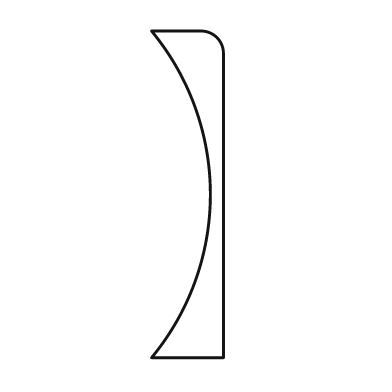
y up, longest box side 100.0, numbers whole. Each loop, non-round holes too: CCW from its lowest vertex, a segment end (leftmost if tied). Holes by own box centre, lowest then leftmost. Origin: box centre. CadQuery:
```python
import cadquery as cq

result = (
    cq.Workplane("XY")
    .moveTo(-11.0, -50.0)
    .lineTo(11.0, -50.0)
    .lineTo(11.0, 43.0)
    .threePointArc((9.0, 48.0), (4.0, 50.0))
    .lineTo(-11.0, 50.0)
    .threePointArc((7.0, 0.0), (-11.0, -50.0))
    .close()
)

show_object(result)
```